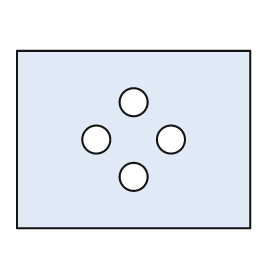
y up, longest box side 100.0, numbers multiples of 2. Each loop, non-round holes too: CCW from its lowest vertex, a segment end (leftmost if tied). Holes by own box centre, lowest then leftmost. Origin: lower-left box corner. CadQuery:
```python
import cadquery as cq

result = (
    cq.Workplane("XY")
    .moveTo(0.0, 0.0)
    .lineTo(100.0, 0.0)
    .lineTo(100.0, 76.0)
    .lineTo(0.0, 76.0)
    .close()
    .moveTo(50.0, 22.0)
    .circle(6.0)
    .moveTo(34.0, 38.0)
    .circle(6.0)
    .moveTo(66.0, 38.0)
    .circle(6.0)
    .moveTo(50.0, 54.0)
    .circle(6.0)
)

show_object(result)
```